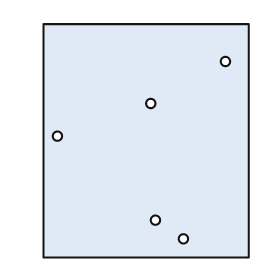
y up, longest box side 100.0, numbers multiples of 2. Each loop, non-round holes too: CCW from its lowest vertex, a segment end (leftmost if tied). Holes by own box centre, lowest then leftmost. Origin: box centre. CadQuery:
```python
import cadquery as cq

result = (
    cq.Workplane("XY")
    .moveTo(-44.0, -50.0)
    .lineTo(44.0, -50.0)
    .lineTo(44.0, 50.0)
    .lineTo(-44.0, 50.0)
    .close()
    .moveTo(16.0, -42.0)
    .circle(2.0)
    .moveTo(4.0, -34.0)
    .circle(2.0)
    .moveTo(-38.0, 2.0)
    .circle(2.0)
    .moveTo(2.0, 16.0)
    .circle(2.0)
    .moveTo(34.0, 34.0)
    .circle(2.0)
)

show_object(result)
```